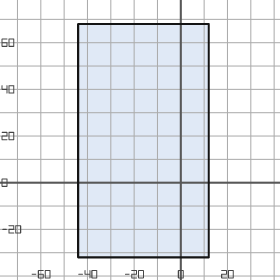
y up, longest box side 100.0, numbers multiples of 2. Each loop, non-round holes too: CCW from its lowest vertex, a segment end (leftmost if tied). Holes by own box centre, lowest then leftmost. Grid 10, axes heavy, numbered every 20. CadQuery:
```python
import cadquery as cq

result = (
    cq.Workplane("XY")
    .moveTo(-44.0, -32.0)
    .lineTo(12.0, -32.0)
    .lineTo(12.0, 68.0)
    .lineTo(-44.0, 68.0)
    .close()
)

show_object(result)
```